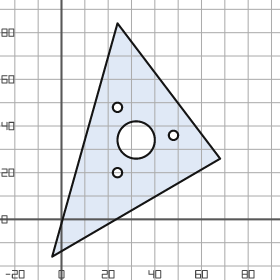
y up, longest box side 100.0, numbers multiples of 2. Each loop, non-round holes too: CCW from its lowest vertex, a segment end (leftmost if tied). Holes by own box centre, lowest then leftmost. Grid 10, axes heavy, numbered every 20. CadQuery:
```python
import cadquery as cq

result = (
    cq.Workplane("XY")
    .moveTo(-4.0, -16.0)
    .lineTo(68.0, 26.0)
    .lineTo(24.0, 84.0)
    .close()
    .moveTo(24.0, 20.0)
    .circle(2.0)
    .moveTo(32.0, 34.0)
    .circle(8.0)
    .moveTo(48.0, 36.0)
    .circle(2.0)
    .moveTo(24.0, 48.0)
    .circle(2.0)
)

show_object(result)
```